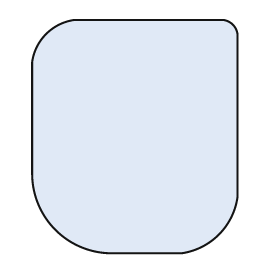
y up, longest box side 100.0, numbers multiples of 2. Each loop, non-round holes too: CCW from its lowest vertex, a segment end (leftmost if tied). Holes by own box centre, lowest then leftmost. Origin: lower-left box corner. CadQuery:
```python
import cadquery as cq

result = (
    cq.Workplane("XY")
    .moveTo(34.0, 0.0)
    .lineTo(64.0, 0.0)
    .threePointArc((80.0, 8.0), (88.0, 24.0))
    .lineTo(88.0, 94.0)
    .threePointArc((86.0, 98.0), (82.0, 100.0))
    .lineTo(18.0, 100.0)
    .threePointArc((6.0, 94.0), (0.0, 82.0))
    .lineTo(0.0, 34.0)
    .threePointArc((10.0, 10.0), (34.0, 0.0))
    .close()
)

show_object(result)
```